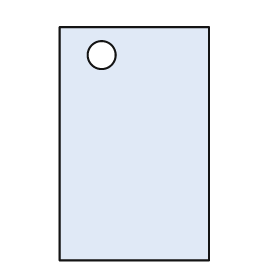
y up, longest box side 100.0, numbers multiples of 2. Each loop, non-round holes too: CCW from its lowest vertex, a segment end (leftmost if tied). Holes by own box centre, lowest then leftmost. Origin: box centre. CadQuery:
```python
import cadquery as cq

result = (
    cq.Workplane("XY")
    .moveTo(-32.0, -50.0)
    .lineTo(32.0, -50.0)
    .lineTo(32.0, 50.0)
    .lineTo(-32.0, 50.0)
    .close()
    .moveTo(-14.0, 38.0)
    .circle(6.0)
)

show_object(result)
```